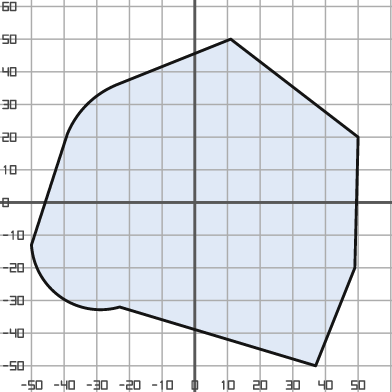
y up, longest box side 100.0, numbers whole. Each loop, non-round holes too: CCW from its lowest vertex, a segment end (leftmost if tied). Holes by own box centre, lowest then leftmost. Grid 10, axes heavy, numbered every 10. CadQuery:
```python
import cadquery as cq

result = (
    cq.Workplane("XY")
    .moveTo(37.0, -50.0)
    .lineTo(49.0, -20.0)
    .lineTo(50.0, 20.0)
    .lineTo(11.0, 50.0)
    .lineTo(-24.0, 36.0)
    .threePointArc((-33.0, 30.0), (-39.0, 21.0))
    .lineTo(-50.0, -13.0)
    .threePointArc((-41.0, -29.0), (-23.0, -32.0))
    .close()
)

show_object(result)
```